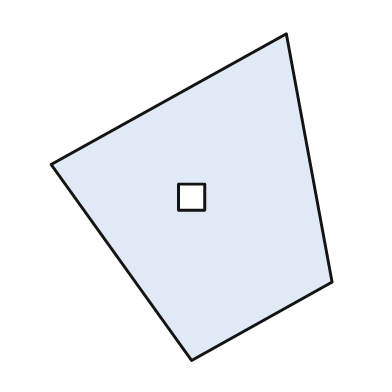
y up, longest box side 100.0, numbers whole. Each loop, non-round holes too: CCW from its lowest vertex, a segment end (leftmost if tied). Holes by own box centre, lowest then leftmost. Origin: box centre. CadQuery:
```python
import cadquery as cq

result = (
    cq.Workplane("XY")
    .moveTo(0.0, -50.0)
    .lineTo(43.0, -26.0)
    .lineTo(29.0, 50.0)
    .lineTo(-43.0, 10.0)
    .close()
    .moveTo(-4.0, -4.0)
    .lineTo(4.0, -4.0)
    .lineTo(4.0, 4.0)
    .lineTo(-4.0, 4.0)
    .close()
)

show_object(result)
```